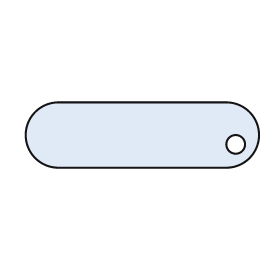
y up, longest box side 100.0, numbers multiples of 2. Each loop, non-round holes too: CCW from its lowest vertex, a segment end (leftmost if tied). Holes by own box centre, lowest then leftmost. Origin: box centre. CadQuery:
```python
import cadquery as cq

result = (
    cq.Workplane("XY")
    .moveTo(-36.0, -14.0)
    .lineTo(36.0, -14.0)
    .threePointArc((50.0, 0.0), (36.0, 14.0))
    .lineTo(-36.0, 14.0)
    .threePointArc((-50.0, 0.0), (-36.0, -14.0))
    .close()
    .moveTo(40.0, -4.0)
    .circle(4.0)
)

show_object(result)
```